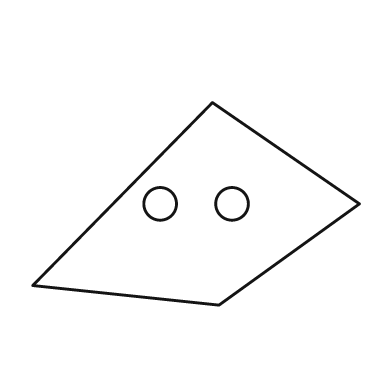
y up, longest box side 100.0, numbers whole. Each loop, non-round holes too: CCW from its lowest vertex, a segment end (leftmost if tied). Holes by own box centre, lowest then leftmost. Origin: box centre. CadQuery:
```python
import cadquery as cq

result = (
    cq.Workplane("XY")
    .moveTo(7.0, -31.0)
    .lineTo(50.0, 0.0)
    .lineTo(5.0, 31.0)
    .lineTo(-50.0, -25.0)
    .close()
    .moveTo(-11.0, 0.0)
    .circle(5.0)
    .moveTo(11.0, 0.0)
    .circle(5.0)
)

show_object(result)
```